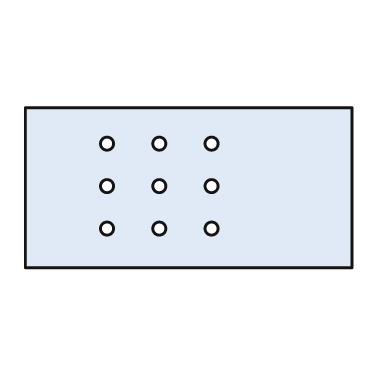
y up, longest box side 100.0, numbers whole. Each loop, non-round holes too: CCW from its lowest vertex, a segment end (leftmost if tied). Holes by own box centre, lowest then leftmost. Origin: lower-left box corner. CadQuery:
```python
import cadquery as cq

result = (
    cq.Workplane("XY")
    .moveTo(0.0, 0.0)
    .lineTo(100.0, 0.0)
    .lineTo(100.0, 49.0)
    .lineTo(0.0, 49.0)
    .close()
    .moveTo(25.0, 12.0)
    .circle(2.0)
    .moveTo(41.0, 12.0)
    .circle(2.0)
    .moveTo(57.0, 12.0)
    .circle(2.0)
    .moveTo(25.0, 25.0)
    .circle(2.0)
    .moveTo(41.0, 25.0)
    .circle(2.0)
    .moveTo(57.0, 25.0)
    .circle(2.0)
    .moveTo(25.0, 38.0)
    .circle(2.0)
    .moveTo(41.0, 38.0)
    .circle(2.0)
    .moveTo(57.0, 38.0)
    .circle(2.0)
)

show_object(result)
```